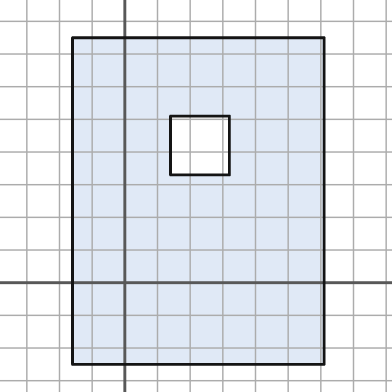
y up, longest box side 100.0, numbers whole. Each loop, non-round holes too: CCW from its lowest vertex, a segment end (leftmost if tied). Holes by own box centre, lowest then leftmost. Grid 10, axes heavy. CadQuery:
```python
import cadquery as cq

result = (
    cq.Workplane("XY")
    .moveTo(-16.0, -25.0)
    .lineTo(61.0, -25.0)
    .lineTo(61.0, 75.0)
    .lineTo(-16.0, 75.0)
    .close()
    .moveTo(14.0, 33.0)
    .lineTo(32.0, 33.0)
    .lineTo(32.0, 51.0)
    .lineTo(14.0, 51.0)
    .close()
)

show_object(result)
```